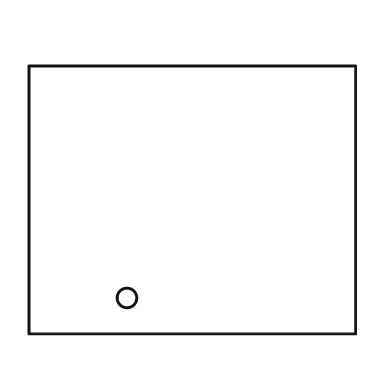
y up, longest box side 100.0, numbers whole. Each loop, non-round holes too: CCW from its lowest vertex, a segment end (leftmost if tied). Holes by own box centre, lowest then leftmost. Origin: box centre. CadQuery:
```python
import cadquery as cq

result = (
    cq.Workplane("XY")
    .moveTo(-50.0, -41.0)
    .lineTo(50.0, -41.0)
    .lineTo(50.0, 41.0)
    .lineTo(-50.0, 41.0)
    .close()
    .moveTo(-20.0, -30.0)
    .circle(3.0)
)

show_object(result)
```